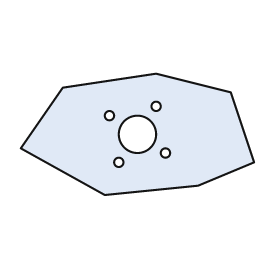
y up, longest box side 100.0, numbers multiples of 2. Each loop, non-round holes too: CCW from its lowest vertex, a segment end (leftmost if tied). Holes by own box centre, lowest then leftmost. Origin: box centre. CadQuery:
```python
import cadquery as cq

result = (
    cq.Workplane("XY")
    .moveTo(-14.0, -26.0)
    .lineTo(26.0, -22.0)
    .lineTo(50.0, -12.0)
    .lineTo(40.0, 18.0)
    .lineTo(8.0, 26.0)
    .lineTo(-32.0, 20.0)
    .lineTo(-50.0, -6.0)
    .close()
    .moveTo(-8.0, -12.0)
    .circle(2.0)
    .moveTo(12.0, -8.0)
    .circle(2.0)
    .moveTo(0.0, 0.0)
    .circle(8.0)
    .moveTo(-12.0, 8.0)
    .circle(2.0)
    .moveTo(8.0, 12.0)
    .circle(2.0)
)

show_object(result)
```